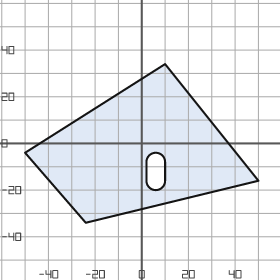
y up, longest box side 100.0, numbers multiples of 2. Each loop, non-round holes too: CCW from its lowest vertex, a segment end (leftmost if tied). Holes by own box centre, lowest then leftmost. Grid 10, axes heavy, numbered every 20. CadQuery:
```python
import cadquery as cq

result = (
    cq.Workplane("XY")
    .moveTo(-24.0, -34.0)
    .lineTo(50.0, -16.0)
    .lineTo(10.0, 34.0)
    .lineTo(-50.0, -4.0)
    .close()
    .moveTo(2.0, -16.0)
    .threePointArc((6.0, -20.0), (10.0, -16.0))
    .lineTo(10.0, -8.0)
    .threePointArc((6.0, -4.0), (2.0, -8.0))
    .close()
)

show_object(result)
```